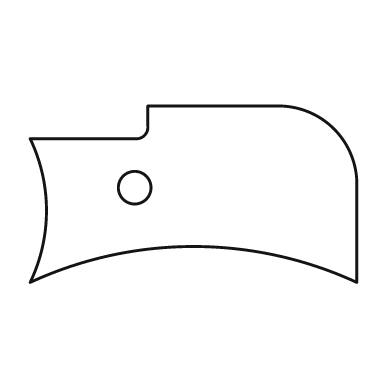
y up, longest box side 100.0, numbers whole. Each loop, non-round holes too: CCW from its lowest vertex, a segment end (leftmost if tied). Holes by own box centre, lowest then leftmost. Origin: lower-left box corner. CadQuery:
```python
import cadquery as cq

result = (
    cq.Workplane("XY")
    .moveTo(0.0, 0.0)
    .threePointArc((50.0, 11.0), (100.0, 0.0))
    .lineTo(100.0, 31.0)
    .threePointArc((93.0, 47.0), (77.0, 54.0))
    .lineTo(36.0, 54.0)
    .lineTo(36.0, 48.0)
    .threePointArc((35.0, 45.0), (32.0, 44.0))
    .lineTo(0.0, 44.0)
    .threePointArc((5.0, 22.0), (0.0, 0.0))
    .close()
    .moveTo(32.0, 29.0)
    .circle(5.0)
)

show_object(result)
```